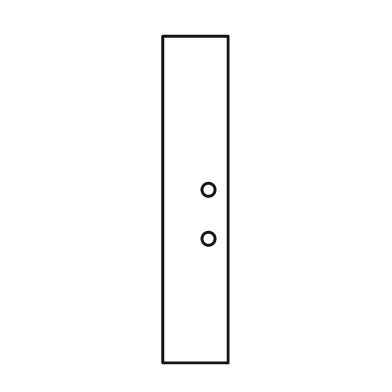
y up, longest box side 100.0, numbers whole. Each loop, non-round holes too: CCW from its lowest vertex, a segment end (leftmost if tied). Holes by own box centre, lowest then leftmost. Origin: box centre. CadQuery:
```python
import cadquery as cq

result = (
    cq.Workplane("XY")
    .moveTo(-10.0, -50.0)
    .lineTo(10.0, -50.0)
    .lineTo(10.0, 50.0)
    .lineTo(-10.0, 50.0)
    .close()
    .moveTo(4.0, -12.0)
    .circle(2.0)
    .moveTo(4.0, 3.0)
    .circle(2.0)
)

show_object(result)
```